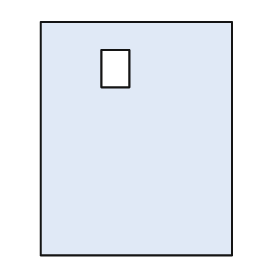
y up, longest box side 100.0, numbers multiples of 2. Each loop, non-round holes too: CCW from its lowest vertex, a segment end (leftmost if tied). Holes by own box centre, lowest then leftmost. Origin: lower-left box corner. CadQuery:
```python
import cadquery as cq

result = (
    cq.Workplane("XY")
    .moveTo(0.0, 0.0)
    .lineTo(82.0, 0.0)
    .lineTo(82.0, 100.0)
    .lineTo(0.0, 100.0)
    .close()
    .moveTo(26.0, 72.0)
    .lineTo(38.0, 72.0)
    .lineTo(38.0, 88.0)
    .lineTo(26.0, 88.0)
    .close()
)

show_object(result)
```